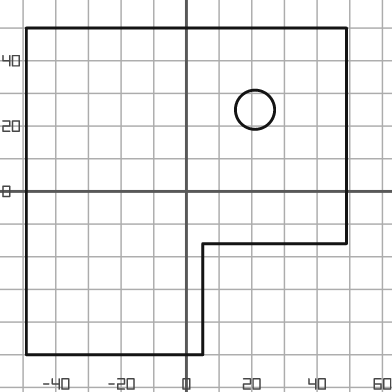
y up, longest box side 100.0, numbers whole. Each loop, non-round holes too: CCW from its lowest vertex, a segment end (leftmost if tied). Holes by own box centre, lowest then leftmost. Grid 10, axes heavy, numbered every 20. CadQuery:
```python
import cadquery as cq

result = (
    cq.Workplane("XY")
    .moveTo(-49.0, -50.0)
    .lineTo(5.0, -50.0)
    .lineTo(5.0, -16.0)
    .lineTo(49.0, -16.0)
    .lineTo(49.0, 50.0)
    .lineTo(-49.0, 50.0)
    .close()
    .moveTo(21.0, 25.0)
    .circle(6.0)
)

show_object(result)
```